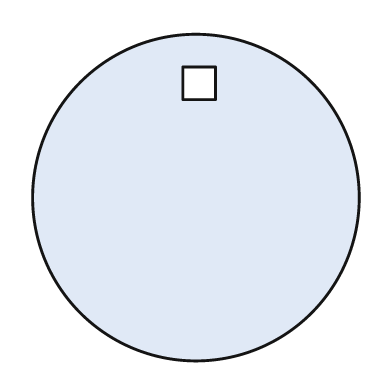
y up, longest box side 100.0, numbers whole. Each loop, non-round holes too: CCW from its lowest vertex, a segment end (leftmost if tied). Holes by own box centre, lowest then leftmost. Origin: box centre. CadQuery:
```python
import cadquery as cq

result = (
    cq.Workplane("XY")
    .moveTo(0.0, 0.0)
    .circle(50.0)
    .moveTo(-4.0, 30.0)
    .lineTo(6.0, 30.0)
    .lineTo(6.0, 40.0)
    .lineTo(-4.0, 40.0)
    .close()
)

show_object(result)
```